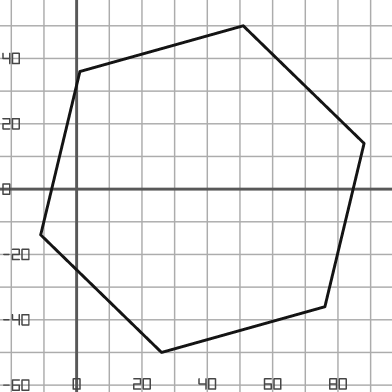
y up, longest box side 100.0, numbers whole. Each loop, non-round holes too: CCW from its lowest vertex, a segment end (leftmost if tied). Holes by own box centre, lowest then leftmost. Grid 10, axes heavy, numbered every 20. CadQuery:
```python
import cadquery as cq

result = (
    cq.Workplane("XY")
    .moveTo(26.0, -50.0)
    .lineTo(76.0, -36.0)
    .lineTo(88.0, 14.0)
    .lineTo(51.0, 50.0)
    .lineTo(1.0, 36.0)
    .lineTo(-11.0, -14.0)
    .close()
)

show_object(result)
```